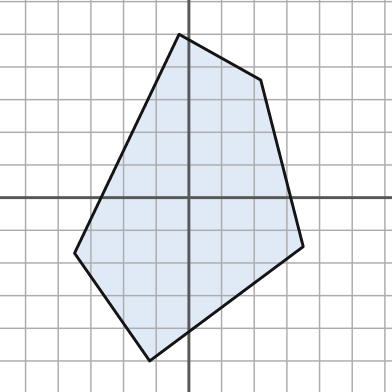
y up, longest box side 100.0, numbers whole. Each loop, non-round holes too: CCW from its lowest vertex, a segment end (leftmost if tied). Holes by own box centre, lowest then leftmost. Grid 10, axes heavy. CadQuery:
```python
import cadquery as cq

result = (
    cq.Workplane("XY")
    .moveTo(-12.0, -50.0)
    .lineTo(35.0, -15.0)
    .lineTo(22.0, 36.0)
    .lineTo(-3.0, 50.0)
    .lineTo(-35.0, -17.0)
    .close()
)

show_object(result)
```